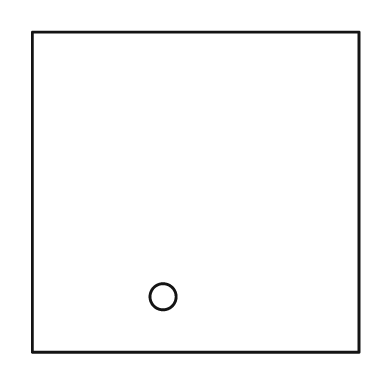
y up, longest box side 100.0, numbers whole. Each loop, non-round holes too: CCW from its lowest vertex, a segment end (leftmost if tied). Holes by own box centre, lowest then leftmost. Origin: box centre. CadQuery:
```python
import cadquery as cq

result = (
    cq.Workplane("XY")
    .moveTo(-50.0, -49.0)
    .lineTo(50.0, -49.0)
    .lineTo(50.0, 49.0)
    .lineTo(-50.0, 49.0)
    .close()
    .moveTo(-10.0, -32.0)
    .circle(4.0)
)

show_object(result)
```